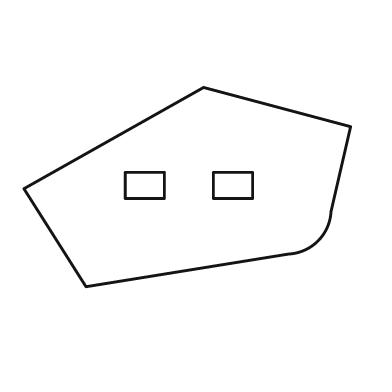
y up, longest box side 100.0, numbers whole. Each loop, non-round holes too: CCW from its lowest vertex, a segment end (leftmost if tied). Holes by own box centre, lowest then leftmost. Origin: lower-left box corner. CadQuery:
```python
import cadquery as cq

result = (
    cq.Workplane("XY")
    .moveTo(19.0, 0.0)
    .lineTo(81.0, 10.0)
    .threePointArc((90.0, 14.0), (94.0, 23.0))
    .lineTo(100.0, 49.0)
    .lineTo(55.0, 61.0)
    .lineTo(0.0, 30.0)
    .close()
    .moveTo(31.0, 27.0)
    .lineTo(43.0, 27.0)
    .lineTo(43.0, 35.0)
    .lineTo(31.0, 35.0)
    .close()
    .moveTo(58.0, 27.0)
    .lineTo(70.0, 27.0)
    .lineTo(70.0, 35.0)
    .lineTo(58.0, 35.0)
    .close()
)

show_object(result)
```